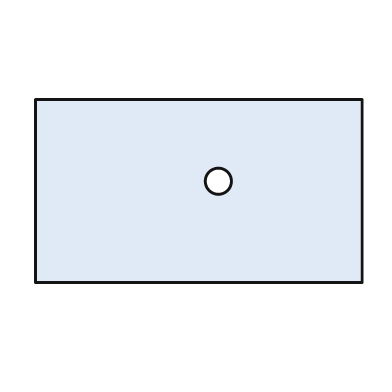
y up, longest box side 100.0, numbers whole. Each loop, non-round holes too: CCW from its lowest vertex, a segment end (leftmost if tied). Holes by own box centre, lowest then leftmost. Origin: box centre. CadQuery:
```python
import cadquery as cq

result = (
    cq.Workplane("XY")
    .moveTo(-50.0, -28.0)
    .lineTo(50.0, -28.0)
    .lineTo(50.0, 28.0)
    .lineTo(-50.0, 28.0)
    .close()
    .moveTo(6.0, 3.0)
    .circle(4.0)
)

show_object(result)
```